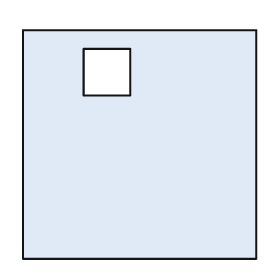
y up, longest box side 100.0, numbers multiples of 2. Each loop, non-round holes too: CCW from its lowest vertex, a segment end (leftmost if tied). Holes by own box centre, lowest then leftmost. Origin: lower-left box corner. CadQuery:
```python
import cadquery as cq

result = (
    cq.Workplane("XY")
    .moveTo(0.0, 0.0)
    .lineTo(100.0, 0.0)
    .lineTo(100.0, 98.0)
    .lineTo(0.0, 98.0)
    .close()
    .moveTo(26.0, 70.0)
    .lineTo(46.0, 70.0)
    .lineTo(46.0, 90.0)
    .lineTo(26.0, 90.0)
    .close()
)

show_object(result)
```